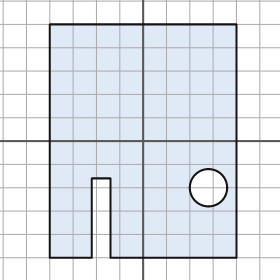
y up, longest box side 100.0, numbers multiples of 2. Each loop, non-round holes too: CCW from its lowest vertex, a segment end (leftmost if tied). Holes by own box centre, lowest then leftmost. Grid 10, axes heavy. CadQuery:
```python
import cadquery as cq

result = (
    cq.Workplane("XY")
    .moveTo(-40.0, -50.0)
    .lineTo(-22.0, -50.0)
    .lineTo(-22.0, -16.0)
    .lineTo(-14.0, -16.0)
    .lineTo(-14.0, -50.0)
    .lineTo(40.0, -50.0)
    .lineTo(40.0, 50.0)
    .lineTo(-40.0, 50.0)
    .close()
    .moveTo(28.0, -20.0)
    .circle(8.0)
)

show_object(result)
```